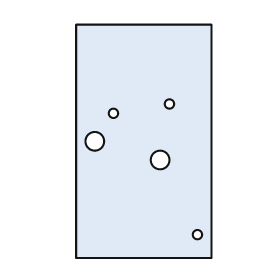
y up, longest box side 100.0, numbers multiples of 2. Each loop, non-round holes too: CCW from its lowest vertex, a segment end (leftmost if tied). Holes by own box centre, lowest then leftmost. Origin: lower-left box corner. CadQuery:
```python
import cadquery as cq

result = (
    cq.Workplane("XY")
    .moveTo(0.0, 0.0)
    .lineTo(58.0, 0.0)
    .lineTo(58.0, 100.0)
    .lineTo(0.0, 100.0)
    .close()
    .moveTo(52.0, 10.0)
    .circle(2.0)
    .moveTo(36.0, 42.0)
    .circle(4.0)
    .moveTo(8.0, 50.0)
    .circle(4.0)
    .moveTo(16.0, 62.0)
    .circle(2.0)
    .moveTo(40.0, 66.0)
    .circle(2.0)
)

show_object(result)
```